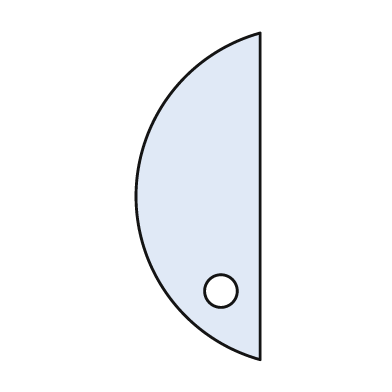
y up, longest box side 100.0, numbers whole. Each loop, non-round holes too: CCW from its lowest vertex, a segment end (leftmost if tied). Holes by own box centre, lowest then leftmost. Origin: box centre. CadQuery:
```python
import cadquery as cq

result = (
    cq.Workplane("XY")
    .moveTo(19.0, -50.0)
    .lineTo(19.0, 50.0)
    .threePointArc((-19.0, 0.0), (19.0, -50.0))
    .close()
    .moveTo(7.0, -29.0)
    .circle(5.0)
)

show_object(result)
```